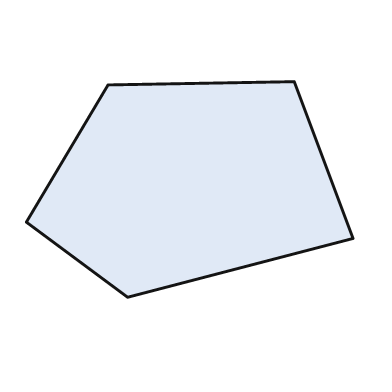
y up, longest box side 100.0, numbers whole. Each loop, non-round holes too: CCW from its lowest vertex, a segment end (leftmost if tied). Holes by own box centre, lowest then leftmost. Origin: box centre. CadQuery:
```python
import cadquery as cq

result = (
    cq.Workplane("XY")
    .moveTo(-19.0, -33.0)
    .lineTo(50.0, -15.0)
    .lineTo(32.0, 33.0)
    .lineTo(-25.0, 32.0)
    .lineTo(-50.0, -10.0)
    .close()
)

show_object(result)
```